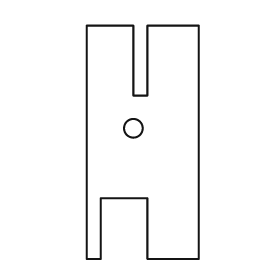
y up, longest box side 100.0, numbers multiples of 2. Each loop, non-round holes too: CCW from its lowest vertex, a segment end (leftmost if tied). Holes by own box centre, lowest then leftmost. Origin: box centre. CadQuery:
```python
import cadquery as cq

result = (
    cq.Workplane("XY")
    .moveTo(-24.0, -50.0)
    .lineTo(-18.0, -50.0)
    .lineTo(-18.0, -24.0)
    .lineTo(2.0, -24.0)
    .lineTo(2.0, -50.0)
    .lineTo(24.0, -50.0)
    .lineTo(24.0, 50.0)
    .lineTo(2.0, 50.0)
    .lineTo(2.0, 20.0)
    .lineTo(-4.0, 20.0)
    .lineTo(-4.0, 50.0)
    .lineTo(-24.0, 50.0)
    .close()
    .moveTo(-4.0, 6.0)
    .circle(4.0)
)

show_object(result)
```